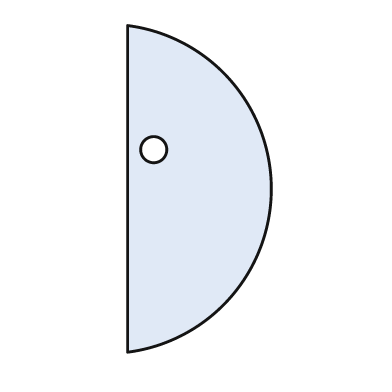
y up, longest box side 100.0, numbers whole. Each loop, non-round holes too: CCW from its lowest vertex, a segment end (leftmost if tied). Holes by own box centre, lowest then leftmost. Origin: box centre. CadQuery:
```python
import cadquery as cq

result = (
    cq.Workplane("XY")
    .moveTo(-22.0, -50.0)
    .threePointArc((22.0, 0.0), (-22.0, 50.0))
    .close()
    .moveTo(-14.0, 12.0)
    .circle(4.0)
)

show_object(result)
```